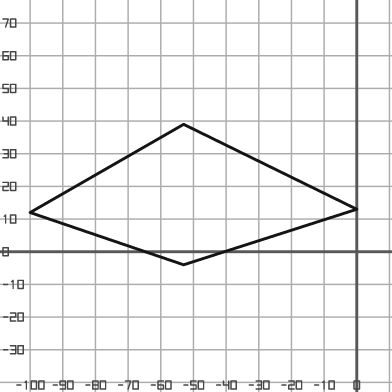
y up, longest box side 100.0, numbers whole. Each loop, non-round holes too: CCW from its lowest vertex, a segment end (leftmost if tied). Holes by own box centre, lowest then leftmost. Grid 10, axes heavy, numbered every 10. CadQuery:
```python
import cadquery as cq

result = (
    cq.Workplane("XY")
    .moveTo(-53.0, -4.0)
    .lineTo(0.0, 13.0)
    .lineTo(-53.0, 39.0)
    .lineTo(-100.0, 12.0)
    .close()
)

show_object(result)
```